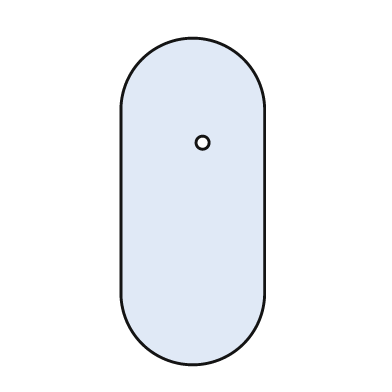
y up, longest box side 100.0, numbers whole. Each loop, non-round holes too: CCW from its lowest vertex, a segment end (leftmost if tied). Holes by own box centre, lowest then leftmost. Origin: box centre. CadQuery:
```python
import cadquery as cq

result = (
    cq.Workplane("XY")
    .moveTo(-22.0, -28.0)
    .threePointArc((0.0, -50.0), (22.0, -28.0))
    .lineTo(22.0, 28.0)
    .threePointArc((0.0, 50.0), (-22.0, 28.0))
    .close()
    .moveTo(3.0, 18.0)
    .circle(2.0)
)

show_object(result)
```